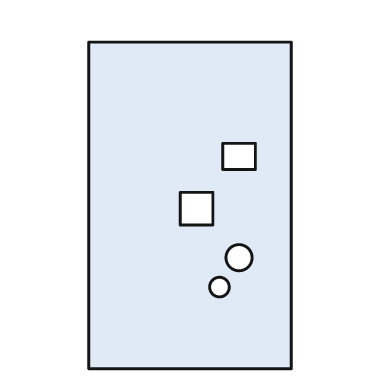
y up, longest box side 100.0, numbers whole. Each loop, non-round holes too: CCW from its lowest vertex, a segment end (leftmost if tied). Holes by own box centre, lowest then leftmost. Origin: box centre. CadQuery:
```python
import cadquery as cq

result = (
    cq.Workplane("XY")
    .moveTo(-31.0, -50.0)
    .lineTo(31.0, -50.0)
    .lineTo(31.0, 50.0)
    .lineTo(-31.0, 50.0)
    .close()
    .moveTo(9.0, -25.0)
    .circle(3.0)
    .moveTo(15.0, -16.0)
    .circle(4.0)
    .moveTo(-3.0, -6.0)
    .lineTo(7.0, -6.0)
    .lineTo(7.0, 4.0)
    .lineTo(-3.0, 4.0)
    .close()
    .moveTo(10.0, 11.0)
    .lineTo(20.0, 11.0)
    .lineTo(20.0, 19.0)
    .lineTo(10.0, 19.0)
    .close()
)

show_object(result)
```